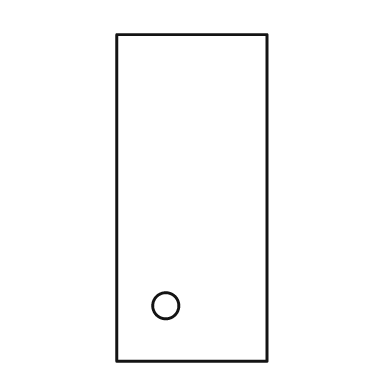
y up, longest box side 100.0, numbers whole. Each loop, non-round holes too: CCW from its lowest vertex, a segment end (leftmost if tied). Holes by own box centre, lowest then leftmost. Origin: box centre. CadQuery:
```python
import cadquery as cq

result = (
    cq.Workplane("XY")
    .moveTo(-23.0, -50.0)
    .lineTo(23.0, -50.0)
    .lineTo(23.0, 50.0)
    .lineTo(-23.0, 50.0)
    .close()
    .moveTo(-8.0, -33.0)
    .circle(4.0)
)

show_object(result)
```